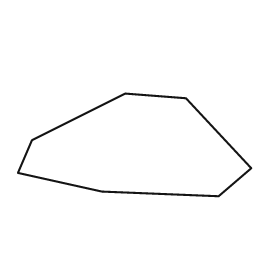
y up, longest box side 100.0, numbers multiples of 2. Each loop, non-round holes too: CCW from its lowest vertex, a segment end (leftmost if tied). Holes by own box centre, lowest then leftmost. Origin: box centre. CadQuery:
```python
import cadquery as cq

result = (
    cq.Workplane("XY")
    .moveTo(36.0, -22.0)
    .lineTo(50.0, -10.0)
    .lineTo(22.0, 20.0)
    .lineTo(-4.0, 22.0)
    .lineTo(-44.0, 2.0)
    .lineTo(-50.0, -12.0)
    .lineTo(-14.0, -20.0)
    .close()
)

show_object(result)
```